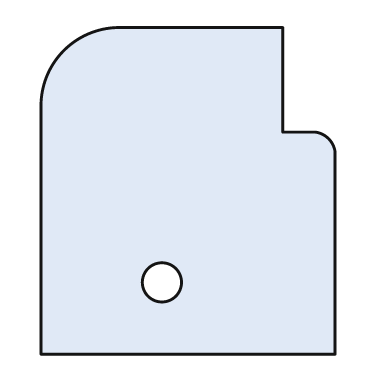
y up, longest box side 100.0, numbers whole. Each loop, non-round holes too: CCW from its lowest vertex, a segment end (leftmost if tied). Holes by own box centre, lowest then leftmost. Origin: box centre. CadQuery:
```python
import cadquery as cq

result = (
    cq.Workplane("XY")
    .moveTo(-45.0, -50.0)
    .lineTo(45.0, -50.0)
    .lineTo(45.0, 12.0)
    .threePointArc((43.0, 16.0), (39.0, 18.0))
    .lineTo(29.0, 18.0)
    .lineTo(29.0, 50.0)
    .lineTo(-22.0, 50.0)
    .threePointArc((-38.0, 43.0), (-45.0, 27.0))
    .close()
    .moveTo(-8.0, -28.0)
    .circle(6.0)
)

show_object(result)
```